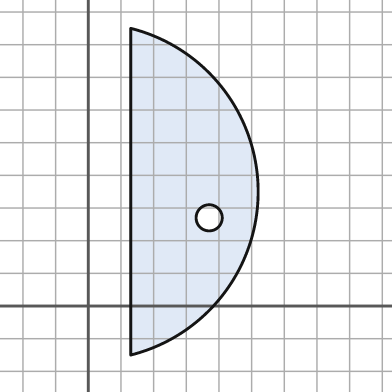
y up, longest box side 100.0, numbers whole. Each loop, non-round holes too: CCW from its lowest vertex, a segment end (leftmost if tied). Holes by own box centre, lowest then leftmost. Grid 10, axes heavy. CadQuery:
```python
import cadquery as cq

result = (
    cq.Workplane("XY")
    .moveTo(13.0, -15.0)
    .threePointArc((52.0, 35.0), (13.0, 85.0))
    .close()
    .moveTo(37.0, 27.0)
    .circle(4.0)
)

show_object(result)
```